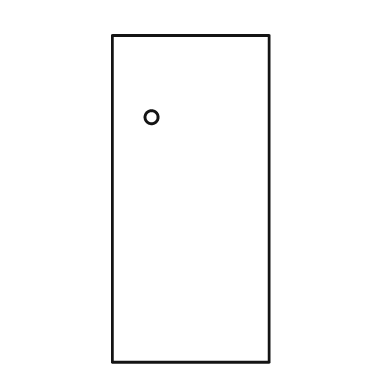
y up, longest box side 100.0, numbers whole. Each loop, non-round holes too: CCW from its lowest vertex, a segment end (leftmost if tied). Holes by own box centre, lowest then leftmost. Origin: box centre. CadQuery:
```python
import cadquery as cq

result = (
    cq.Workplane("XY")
    .moveTo(-24.0, -50.0)
    .lineTo(24.0, -50.0)
    .lineTo(24.0, 50.0)
    .lineTo(-24.0, 50.0)
    .close()
    .moveTo(-12.0, 25.0)
    .circle(2.0)
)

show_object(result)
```